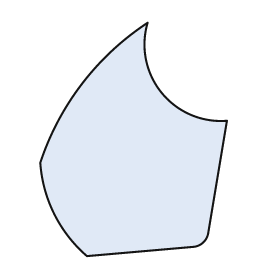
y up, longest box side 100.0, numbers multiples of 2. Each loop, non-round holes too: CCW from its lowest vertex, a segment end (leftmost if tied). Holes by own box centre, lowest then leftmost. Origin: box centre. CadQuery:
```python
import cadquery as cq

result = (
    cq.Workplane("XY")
    .moveTo(-20.0, -50.0)
    .lineTo(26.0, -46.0)
    .threePointArc((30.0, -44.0), (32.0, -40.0))
    .lineTo(40.0, 8.0)
    .threePointArc((12.0, 20.0), (6.0, 50.0))
    .threePointArc((-22.0, 24.0), (-40.0, -10.0))
    .threePointArc((-34.0, -32.0), (-20.0, -50.0))
    .close()
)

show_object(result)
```